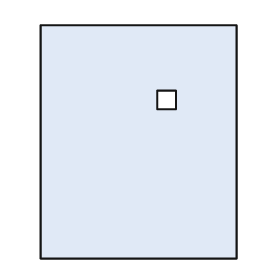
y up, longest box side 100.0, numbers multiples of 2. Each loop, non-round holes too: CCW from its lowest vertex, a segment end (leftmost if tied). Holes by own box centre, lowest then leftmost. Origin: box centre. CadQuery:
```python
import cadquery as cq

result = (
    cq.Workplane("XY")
    .moveTo(-42.0, -50.0)
    .lineTo(42.0, -50.0)
    .lineTo(42.0, 50.0)
    .lineTo(-42.0, 50.0)
    .close()
    .moveTo(8.0, 14.0)
    .lineTo(16.0, 14.0)
    .lineTo(16.0, 22.0)
    .lineTo(8.0, 22.0)
    .close()
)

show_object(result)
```